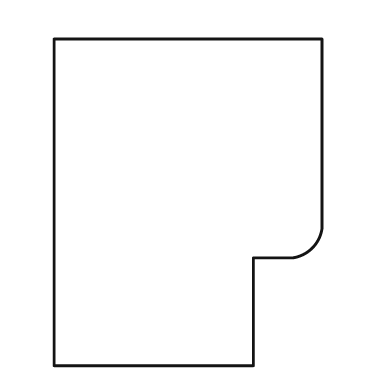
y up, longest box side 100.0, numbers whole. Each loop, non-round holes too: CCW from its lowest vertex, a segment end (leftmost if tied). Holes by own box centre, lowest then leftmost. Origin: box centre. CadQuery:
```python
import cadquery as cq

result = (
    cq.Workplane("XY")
    .moveTo(-41.0, -50.0)
    .lineTo(20.0, -50.0)
    .lineTo(20.0, -17.0)
    .lineTo(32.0, -17.0)
    .threePointArc((38.0, -14.0), (41.0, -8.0))
    .lineTo(41.0, 50.0)
    .lineTo(-41.0, 50.0)
    .close()
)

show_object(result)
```